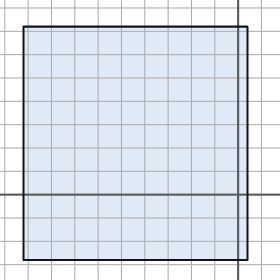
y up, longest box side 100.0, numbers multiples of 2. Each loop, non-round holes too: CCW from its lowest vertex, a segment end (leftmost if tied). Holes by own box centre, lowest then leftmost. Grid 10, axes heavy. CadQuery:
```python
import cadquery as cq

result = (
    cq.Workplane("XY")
    .moveTo(-92.0, -28.0)
    .lineTo(4.0, -28.0)
    .lineTo(4.0, 72.0)
    .lineTo(-92.0, 72.0)
    .close()
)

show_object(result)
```